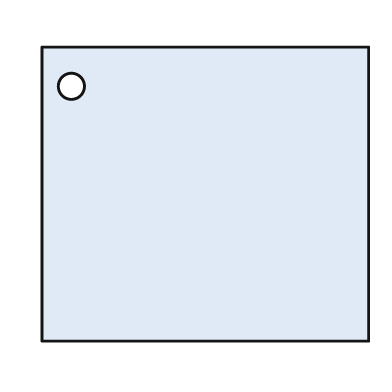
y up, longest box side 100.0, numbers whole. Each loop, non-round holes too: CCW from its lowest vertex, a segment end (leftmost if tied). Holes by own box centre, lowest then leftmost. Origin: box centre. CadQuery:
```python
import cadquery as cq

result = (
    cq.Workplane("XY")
    .moveTo(-50.0, -45.0)
    .lineTo(50.0, -45.0)
    .lineTo(50.0, 45.0)
    .lineTo(-50.0, 45.0)
    .close()
    .moveTo(-41.0, 33.0)
    .circle(4.0)
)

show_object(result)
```